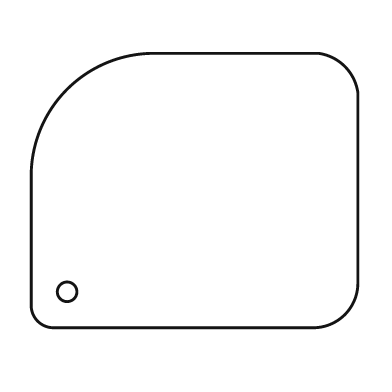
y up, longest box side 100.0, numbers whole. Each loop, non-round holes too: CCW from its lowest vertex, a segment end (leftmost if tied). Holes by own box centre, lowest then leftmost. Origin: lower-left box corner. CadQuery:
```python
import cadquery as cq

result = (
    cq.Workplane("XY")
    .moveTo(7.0, 0.0)
    .lineTo(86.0, 0.0)
    .threePointArc((96.0, 4.0), (100.0, 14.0))
    .lineTo(100.0, 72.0)
    .threePointArc((96.0, 80.0), (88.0, 84.0))
    .lineTo(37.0, 84.0)
    .threePointArc((11.0, 73.0), (0.0, 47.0))
    .lineTo(0.0, 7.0)
    .threePointArc((2.0, 2.0), (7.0, 0.0))
    .close()
    .moveTo(11.0, 11.0)
    .circle(3.0)
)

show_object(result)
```